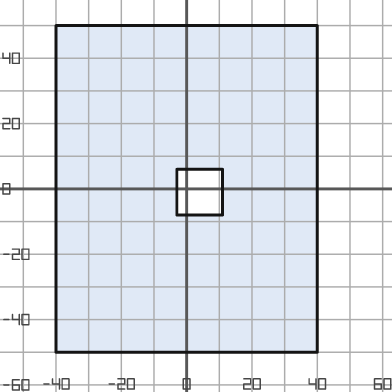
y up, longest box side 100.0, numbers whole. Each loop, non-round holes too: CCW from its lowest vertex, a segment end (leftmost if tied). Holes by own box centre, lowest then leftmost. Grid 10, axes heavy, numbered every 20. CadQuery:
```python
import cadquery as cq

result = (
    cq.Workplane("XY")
    .moveTo(-40.0, -50.0)
    .lineTo(40.0, -50.0)
    .lineTo(40.0, 50.0)
    .lineTo(-40.0, 50.0)
    .close()
    .moveTo(-3.0, -8.0)
    .lineTo(11.0, -8.0)
    .lineTo(11.0, 6.0)
    .lineTo(-3.0, 6.0)
    .close()
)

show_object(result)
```